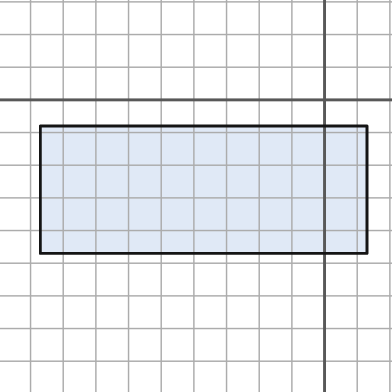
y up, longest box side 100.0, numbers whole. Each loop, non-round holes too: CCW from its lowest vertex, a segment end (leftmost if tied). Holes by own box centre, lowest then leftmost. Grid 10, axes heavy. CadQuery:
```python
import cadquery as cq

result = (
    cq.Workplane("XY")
    .moveTo(-87.0, -47.0)
    .lineTo(13.0, -47.0)
    .lineTo(13.0, -8.0)
    .lineTo(-87.0, -8.0)
    .close()
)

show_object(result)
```